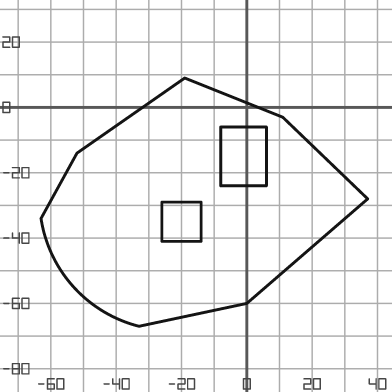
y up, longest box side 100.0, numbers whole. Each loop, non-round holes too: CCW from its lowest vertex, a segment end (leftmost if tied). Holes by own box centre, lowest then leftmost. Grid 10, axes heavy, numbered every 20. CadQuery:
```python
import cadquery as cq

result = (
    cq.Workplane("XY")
    .moveTo(-33.0, -67.0)
    .lineTo(0.0, -60.0)
    .lineTo(37.0, -28.0)
    .lineTo(11.0, -3.0)
    .lineTo(-19.0, 9.0)
    .lineTo(-52.0, -14.0)
    .lineTo(-63.0, -34.0)
    .threePointArc((-53.0, -55.0), (-33.0, -67.0))
    .close()
    .moveTo(-26.0, -41.0)
    .lineTo(-14.0, -41.0)
    .lineTo(-14.0, -29.0)
    .lineTo(-26.0, -29.0)
    .close()
    .moveTo(-8.0, -24.0)
    .lineTo(6.0, -24.0)
    .lineTo(6.0, -6.0)
    .lineTo(-8.0, -6.0)
    .close()
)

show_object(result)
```